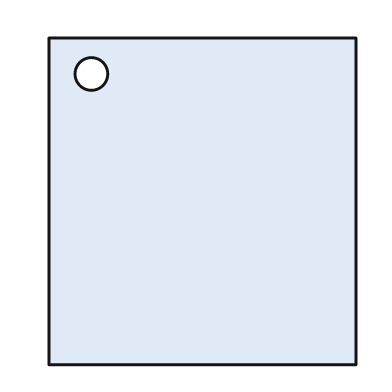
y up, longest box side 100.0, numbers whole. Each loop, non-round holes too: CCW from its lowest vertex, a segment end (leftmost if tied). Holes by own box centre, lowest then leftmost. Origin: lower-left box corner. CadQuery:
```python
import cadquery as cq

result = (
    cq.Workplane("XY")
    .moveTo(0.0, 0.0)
    .lineTo(94.0, 0.0)
    .lineTo(94.0, 100.0)
    .lineTo(0.0, 100.0)
    .close()
    .moveTo(13.0, 89.0)
    .circle(5.0)
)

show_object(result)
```